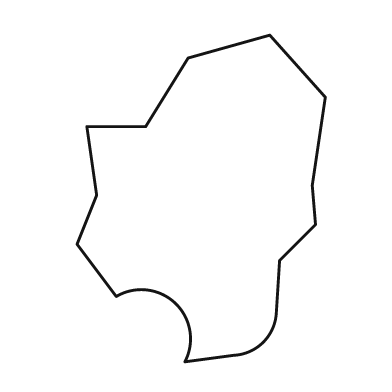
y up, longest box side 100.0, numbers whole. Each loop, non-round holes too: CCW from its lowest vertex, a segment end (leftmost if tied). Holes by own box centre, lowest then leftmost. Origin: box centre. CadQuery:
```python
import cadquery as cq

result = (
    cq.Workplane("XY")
    .moveTo(-5.0, -50.0)
    .lineTo(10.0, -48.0)
    .threePointArc((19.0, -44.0), (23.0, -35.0))
    .lineTo(24.0, -19.0)
    .lineTo(35.0, -8.0)
    .lineTo(34.0, 4.0)
    .lineTo(38.0, 31.0)
    .lineTo(21.0, 50.0)
    .lineTo(-4.0, 43.0)
    .lineTo(-17.0, 22.0)
    .lineTo(-35.0, 22.0)
    .lineTo(-32.0, 1.0)
    .lineTo(-38.0, -14.0)
    .lineTo(-26.0, -30.0)
    .threePointArc((-8.0, -32.0), (-5.0, -50.0))
    .close()
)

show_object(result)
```